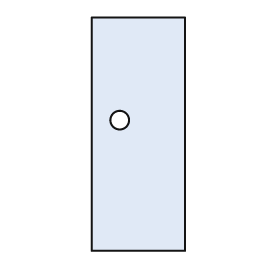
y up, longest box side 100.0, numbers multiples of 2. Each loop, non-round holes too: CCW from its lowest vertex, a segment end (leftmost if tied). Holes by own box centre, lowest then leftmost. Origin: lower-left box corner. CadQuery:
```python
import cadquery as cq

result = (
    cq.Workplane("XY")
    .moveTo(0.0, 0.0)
    .lineTo(40.0, 0.0)
    .lineTo(40.0, 100.0)
    .lineTo(0.0, 100.0)
    .close()
    .moveTo(12.0, 56.0)
    .circle(4.0)
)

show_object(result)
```